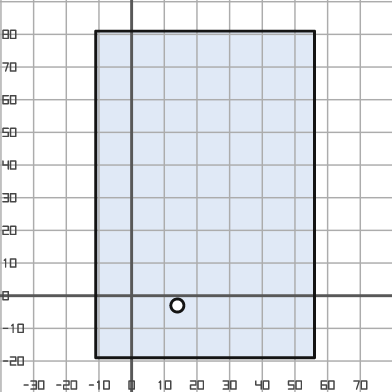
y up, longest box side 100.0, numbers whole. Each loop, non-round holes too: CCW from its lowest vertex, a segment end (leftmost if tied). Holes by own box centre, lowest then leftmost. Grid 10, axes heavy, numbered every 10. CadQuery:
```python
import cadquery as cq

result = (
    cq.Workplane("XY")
    .moveTo(-11.0, -19.0)
    .lineTo(56.0, -19.0)
    .lineTo(56.0, 81.0)
    .lineTo(-11.0, 81.0)
    .close()
    .moveTo(14.0, -3.0)
    .circle(2.0)
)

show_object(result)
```